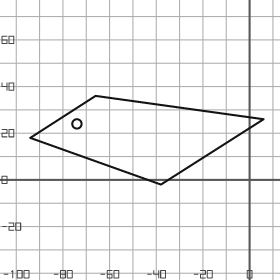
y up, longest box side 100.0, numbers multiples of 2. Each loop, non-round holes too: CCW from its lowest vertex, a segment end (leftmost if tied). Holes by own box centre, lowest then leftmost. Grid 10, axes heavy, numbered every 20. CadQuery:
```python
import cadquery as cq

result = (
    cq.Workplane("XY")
    .moveTo(-38.0, -2.0)
    .lineTo(6.0, 26.0)
    .lineTo(-66.0, 36.0)
    .lineTo(-94.0, 18.0)
    .close()
    .moveTo(-74.0, 24.0)
    .circle(2.0)
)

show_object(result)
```